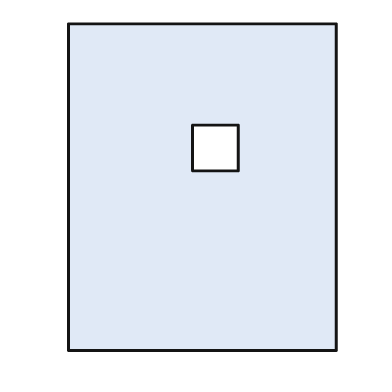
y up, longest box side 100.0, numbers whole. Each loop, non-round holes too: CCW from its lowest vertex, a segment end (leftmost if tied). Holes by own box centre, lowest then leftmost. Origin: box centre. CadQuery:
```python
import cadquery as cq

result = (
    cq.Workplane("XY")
    .moveTo(-41.0, -50.0)
    .lineTo(41.0, -50.0)
    .lineTo(41.0, 50.0)
    .lineTo(-41.0, 50.0)
    .close()
    .moveTo(-3.0, 5.0)
    .lineTo(11.0, 5.0)
    .lineTo(11.0, 19.0)
    .lineTo(-3.0, 19.0)
    .close()
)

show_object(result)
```